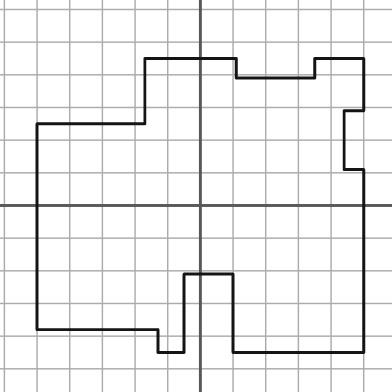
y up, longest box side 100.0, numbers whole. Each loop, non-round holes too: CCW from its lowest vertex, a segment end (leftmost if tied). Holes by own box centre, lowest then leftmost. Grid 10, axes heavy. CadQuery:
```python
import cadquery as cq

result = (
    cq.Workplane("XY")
    .moveTo(-13.0, -45.0)
    .lineTo(-5.0, -45.0)
    .lineTo(-5.0, -21.0)
    .lineTo(10.0, -21.0)
    .lineTo(10.0, -45.0)
    .lineTo(50.0, -45.0)
    .lineTo(50.0, 11.0)
    .lineTo(44.0, 11.0)
    .lineTo(44.0, 29.0)
    .lineTo(50.0, 29.0)
    .lineTo(50.0, 45.0)
    .lineTo(35.0, 45.0)
    .lineTo(35.0, 39.0)
    .lineTo(11.0, 39.0)
    .lineTo(11.0, 45.0)
    .lineTo(-17.0, 45.0)
    .lineTo(-17.0, 25.0)
    .lineTo(-50.0, 25.0)
    .lineTo(-50.0, -38.0)
    .lineTo(-13.0, -38.0)
    .close()
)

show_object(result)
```